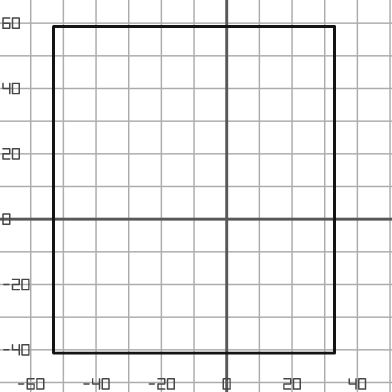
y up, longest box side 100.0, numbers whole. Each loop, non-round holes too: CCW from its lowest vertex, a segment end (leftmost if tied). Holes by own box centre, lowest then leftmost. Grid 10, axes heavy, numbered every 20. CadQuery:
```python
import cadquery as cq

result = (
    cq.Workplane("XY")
    .moveTo(-53.0, -41.0)
    .lineTo(33.0, -41.0)
    .lineTo(33.0, 59.0)
    .lineTo(-53.0, 59.0)
    .close()
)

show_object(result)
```